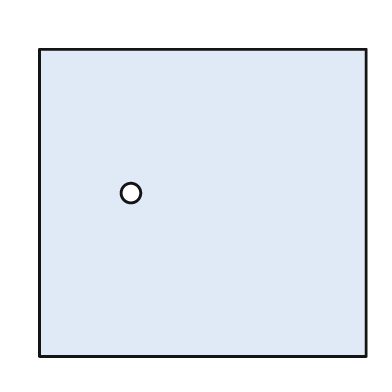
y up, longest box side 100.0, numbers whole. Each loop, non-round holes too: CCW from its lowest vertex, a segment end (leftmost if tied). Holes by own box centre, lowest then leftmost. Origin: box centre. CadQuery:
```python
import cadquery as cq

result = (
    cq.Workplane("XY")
    .moveTo(-50.0, -47.0)
    .lineTo(50.0, -47.0)
    .lineTo(50.0, 47.0)
    .lineTo(-50.0, 47.0)
    .close()
    .moveTo(-22.0, 3.0)
    .circle(3.0)
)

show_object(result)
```